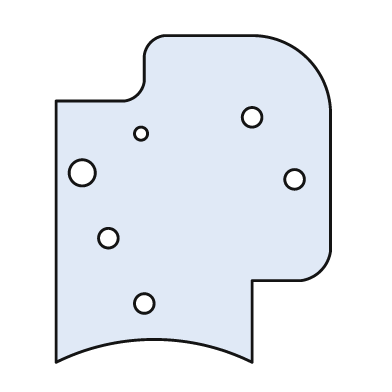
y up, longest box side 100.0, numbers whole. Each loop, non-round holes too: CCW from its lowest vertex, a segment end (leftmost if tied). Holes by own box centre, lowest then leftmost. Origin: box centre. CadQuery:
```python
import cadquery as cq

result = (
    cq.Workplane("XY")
    .moveTo(-42.0, -50.0)
    .threePointArc((-12.0, -43.0), (18.0, -50.0))
    .lineTo(18.0, -25.0)
    .lineTo(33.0, -25.0)
    .threePointArc((39.0, -22.0), (42.0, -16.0))
    .lineTo(42.0, 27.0)
    .threePointArc((35.0, 43.0), (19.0, 50.0))
    .lineTo(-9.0, 50.0)
    .threePointArc((-13.0, 48.0), (-15.0, 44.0))
    .lineTo(-15.0, 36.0)
    .threePointArc((-17.0, 32.0), (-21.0, 30.0))
    .lineTo(-42.0, 30.0)
    .close()
    .moveTo(-15.0, -32.0)
    .circle(3.0)
    .moveTo(-26.0, -12.0)
    .circle(3.0)
    .moveTo(31.0, 6.0)
    .circle(3.0)
    .moveTo(-34.0, 8.0)
    .circle(4.0)
    .moveTo(-16.0, 20.0)
    .circle(2.0)
    .moveTo(18.0, 25.0)
    .circle(3.0)
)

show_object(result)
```